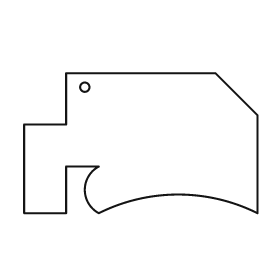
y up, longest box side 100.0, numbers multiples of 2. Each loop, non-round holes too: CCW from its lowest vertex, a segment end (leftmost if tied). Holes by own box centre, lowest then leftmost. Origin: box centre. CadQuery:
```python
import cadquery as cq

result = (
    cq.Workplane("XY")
    .moveTo(-50.0, -30.0)
    .lineTo(-32.0, -30.0)
    .lineTo(-32.0, -10.0)
    .lineTo(-18.0, -10.0)
    .threePointArc((-24.0, -20.0), (-18.0, -30.0))
    .threePointArc((16.0, -22.0), (50.0, -30.0))
    .lineTo(50.0, 12.0)
    .lineTo(32.0, 30.0)
    .lineTo(-32.0, 30.0)
    .lineTo(-32.0, 8.0)
    .lineTo(-50.0, 8.0)
    .close()
    .moveTo(-24.0, 24.0)
    .circle(2.0)
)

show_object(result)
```